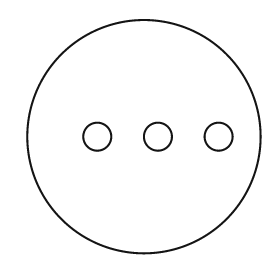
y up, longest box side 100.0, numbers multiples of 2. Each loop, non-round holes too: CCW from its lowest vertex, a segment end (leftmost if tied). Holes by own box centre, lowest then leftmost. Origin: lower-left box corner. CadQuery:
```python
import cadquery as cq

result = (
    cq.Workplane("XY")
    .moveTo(50.0, 50.0)
    .circle(50.0)
    .moveTo(30.0, 50.0)
    .circle(6.0)
    .moveTo(56.0, 50.0)
    .circle(6.0)
    .moveTo(82.0, 50.0)
    .circle(6.0)
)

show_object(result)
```